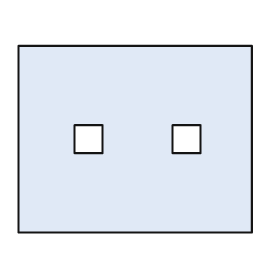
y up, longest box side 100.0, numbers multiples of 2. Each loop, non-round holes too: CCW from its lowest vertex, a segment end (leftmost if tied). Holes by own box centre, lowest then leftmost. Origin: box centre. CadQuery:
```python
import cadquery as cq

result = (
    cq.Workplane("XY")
    .moveTo(-50.0, -40.0)
    .lineTo(50.0, -40.0)
    .lineTo(50.0, 40.0)
    .lineTo(-50.0, 40.0)
    .close()
    .moveTo(-26.0, -6.0)
    .lineTo(-14.0, -6.0)
    .lineTo(-14.0, 6.0)
    .lineTo(-26.0, 6.0)
    .close()
    .moveTo(16.0, -6.0)
    .lineTo(28.0, -6.0)
    .lineTo(28.0, 6.0)
    .lineTo(16.0, 6.0)
    .close()
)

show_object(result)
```